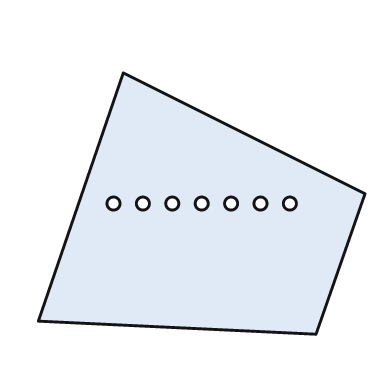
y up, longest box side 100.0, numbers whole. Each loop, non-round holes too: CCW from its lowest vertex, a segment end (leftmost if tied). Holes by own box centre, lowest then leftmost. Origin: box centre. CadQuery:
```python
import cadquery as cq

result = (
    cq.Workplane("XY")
    .moveTo(35.0, -40.0)
    .lineTo(50.0, 3.0)
    .lineTo(-24.0, 40.0)
    .lineTo(-50.0, -36.0)
    .close()
    .moveTo(-27.0, 0.0)
    .circle(2.0)
    .moveTo(-18.0, 0.0)
    .circle(2.0)
    .moveTo(-9.0, 0.0)
    .circle(2.0)
    .moveTo(0.0, 0.0)
    .circle(2.0)
    .moveTo(9.0, 0.0)
    .circle(2.0)
    .moveTo(18.0, 0.0)
    .circle(2.0)
    .moveTo(27.0, 0.0)
    .circle(2.0)
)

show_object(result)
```